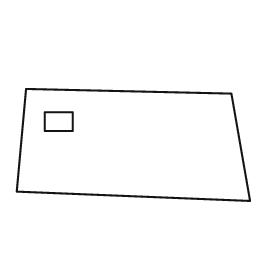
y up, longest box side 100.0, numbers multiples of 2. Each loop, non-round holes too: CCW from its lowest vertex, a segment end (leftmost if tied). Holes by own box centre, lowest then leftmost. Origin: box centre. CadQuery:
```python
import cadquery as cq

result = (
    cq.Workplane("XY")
    .moveTo(50.0, -24.0)
    .lineTo(42.0, 22.0)
    .lineTo(-46.0, 24.0)
    .lineTo(-50.0, -20.0)
    .close()
    .moveTo(-38.0, 6.0)
    .lineTo(-26.0, 6.0)
    .lineTo(-26.0, 14.0)
    .lineTo(-38.0, 14.0)
    .close()
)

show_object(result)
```